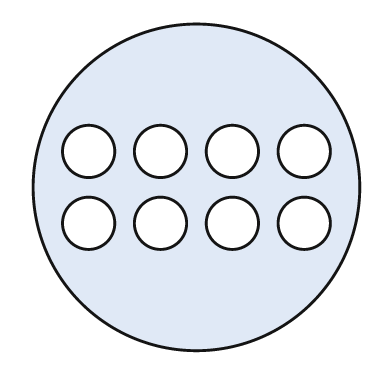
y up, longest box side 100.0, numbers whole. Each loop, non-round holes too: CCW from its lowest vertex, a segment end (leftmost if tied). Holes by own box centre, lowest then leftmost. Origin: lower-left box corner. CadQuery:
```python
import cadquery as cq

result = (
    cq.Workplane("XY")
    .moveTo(50.0, 50.0)
    .circle(50.0)
    .moveTo(17.0, 39.0)
    .circle(8.0)
    .moveTo(39.0, 39.0)
    .circle(8.0)
    .moveTo(61.0, 39.0)
    .circle(8.0)
    .moveTo(83.0, 39.0)
    .circle(8.0)
    .moveTo(17.0, 61.0)
    .circle(8.0)
    .moveTo(39.0, 61.0)
    .circle(8.0)
    .moveTo(61.0, 61.0)
    .circle(8.0)
    .moveTo(83.0, 61.0)
    .circle(8.0)
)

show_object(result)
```